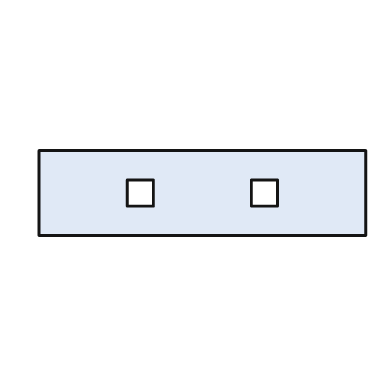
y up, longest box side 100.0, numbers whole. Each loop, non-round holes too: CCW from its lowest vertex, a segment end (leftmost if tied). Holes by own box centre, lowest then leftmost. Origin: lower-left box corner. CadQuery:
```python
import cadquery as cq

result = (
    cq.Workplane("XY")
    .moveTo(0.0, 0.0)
    .lineTo(100.0, 0.0)
    .lineTo(100.0, 26.0)
    .lineTo(0.0, 26.0)
    .close()
    .moveTo(27.0, 9.0)
    .lineTo(35.0, 9.0)
    .lineTo(35.0, 17.0)
    .lineTo(27.0, 17.0)
    .close()
    .moveTo(65.0, 9.0)
    .lineTo(73.0, 9.0)
    .lineTo(73.0, 17.0)
    .lineTo(65.0, 17.0)
    .close()
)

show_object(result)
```